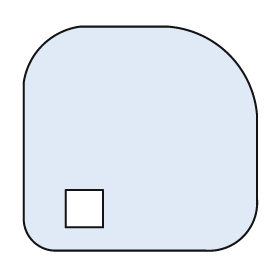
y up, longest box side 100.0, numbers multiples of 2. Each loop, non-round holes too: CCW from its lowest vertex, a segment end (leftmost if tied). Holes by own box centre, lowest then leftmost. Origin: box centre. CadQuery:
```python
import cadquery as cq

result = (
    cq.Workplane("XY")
    .moveTo(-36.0, -48.0)
    .lineTo(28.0, -48.0)
    .threePointArc((44.0, -42.0), (50.0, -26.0))
    .lineTo(50.0, 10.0)
    .threePointArc((38.0, 36.0), (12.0, 48.0))
    .lineTo(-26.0, 48.0)
    .threePointArc((-42.0, 40.0), (-50.0, 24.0))
    .lineTo(-50.0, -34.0)
    .threePointArc((-46.0, -44.0), (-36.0, -48.0))
    .close()
    .moveTo(-32.0, -38.0)
    .lineTo(-16.0, -38.0)
    .lineTo(-16.0, -22.0)
    .lineTo(-32.0, -22.0)
    .close()
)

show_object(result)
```